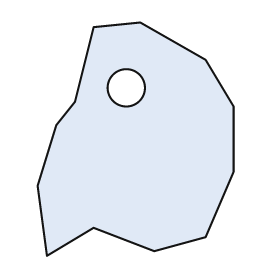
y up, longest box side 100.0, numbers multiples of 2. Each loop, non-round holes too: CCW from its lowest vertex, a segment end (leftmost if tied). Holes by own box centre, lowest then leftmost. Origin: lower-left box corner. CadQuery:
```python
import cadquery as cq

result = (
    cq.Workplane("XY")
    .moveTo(4.0, 0.0)
    .lineTo(24.0, 12.0)
    .lineTo(50.0, 2.0)
    .lineTo(72.0, 8.0)
    .lineTo(84.0, 36.0)
    .lineTo(84.0, 64.0)
    .lineTo(72.0, 84.0)
    .lineTo(44.0, 100.0)
    .lineTo(24.0, 98.0)
    .lineTo(16.0, 66.0)
    .lineTo(8.0, 56.0)
    .lineTo(0.0, 30.0)
    .close()
    .moveTo(38.0, 72.0)
    .circle(8.0)
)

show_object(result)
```